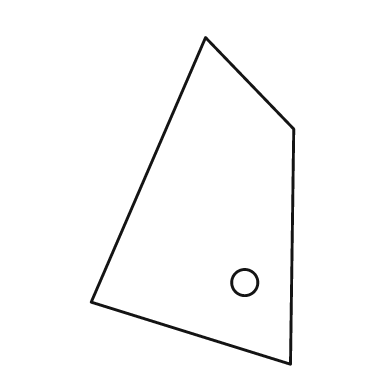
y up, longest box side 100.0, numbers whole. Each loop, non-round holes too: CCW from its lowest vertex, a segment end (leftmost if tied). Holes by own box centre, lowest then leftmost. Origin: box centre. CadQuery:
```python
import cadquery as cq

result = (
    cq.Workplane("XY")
    .moveTo(30.0, -50.0)
    .lineTo(31.0, 22.0)
    .lineTo(4.0, 50.0)
    .lineTo(-31.0, -31.0)
    .close()
    .moveTo(16.0, -25.0)
    .circle(4.0)
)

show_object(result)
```